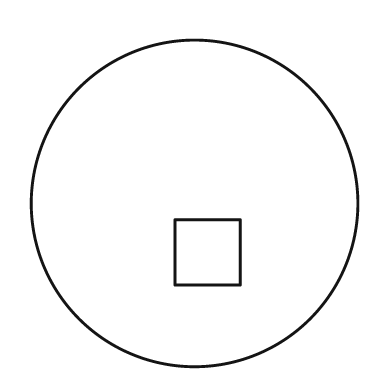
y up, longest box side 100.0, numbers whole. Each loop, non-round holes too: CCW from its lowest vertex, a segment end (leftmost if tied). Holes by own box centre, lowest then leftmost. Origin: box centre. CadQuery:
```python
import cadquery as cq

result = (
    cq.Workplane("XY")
    .moveTo(0.0, 0.0)
    .circle(50.0)
    .moveTo(-6.0, -25.0)
    .lineTo(14.0, -25.0)
    .lineTo(14.0, -5.0)
    .lineTo(-6.0, -5.0)
    .close()
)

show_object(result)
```